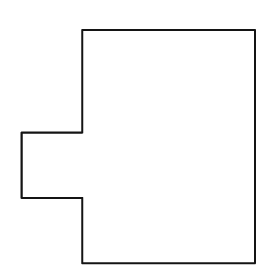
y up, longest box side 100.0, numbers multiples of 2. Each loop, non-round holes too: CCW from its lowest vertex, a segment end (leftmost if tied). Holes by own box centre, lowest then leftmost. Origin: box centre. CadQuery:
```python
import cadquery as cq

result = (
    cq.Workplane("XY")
    .moveTo(-24.0, -50.0)
    .lineTo(50.0, -50.0)
    .lineTo(50.0, 50.0)
    .lineTo(-24.0, 50.0)
    .lineTo(-24.0, 6.0)
    .lineTo(-50.0, 6.0)
    .lineTo(-50.0, -22.0)
    .lineTo(-24.0, -22.0)
    .close()
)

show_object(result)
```